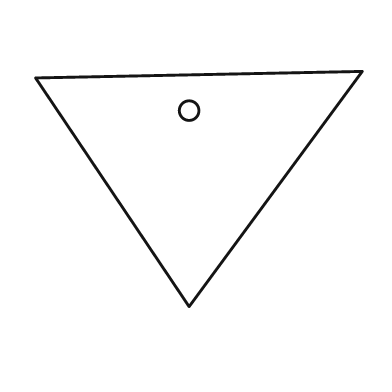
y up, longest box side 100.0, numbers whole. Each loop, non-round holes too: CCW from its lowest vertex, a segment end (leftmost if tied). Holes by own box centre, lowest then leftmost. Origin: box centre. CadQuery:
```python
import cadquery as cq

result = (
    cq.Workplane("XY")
    .moveTo(-3.0, -36.0)
    .lineTo(50.0, 36.0)
    .lineTo(-50.0, 34.0)
    .close()
    .moveTo(-3.0, 24.0)
    .circle(3.0)
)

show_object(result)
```